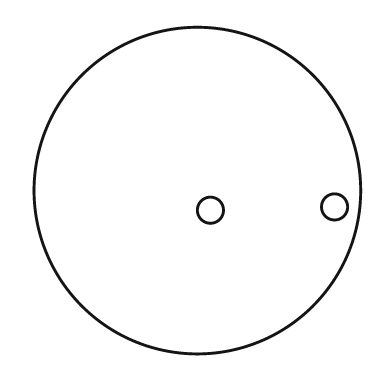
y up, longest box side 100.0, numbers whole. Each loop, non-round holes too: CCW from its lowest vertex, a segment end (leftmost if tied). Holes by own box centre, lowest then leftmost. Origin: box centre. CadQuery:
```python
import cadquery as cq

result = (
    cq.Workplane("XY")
    .moveTo(0.0, 0.0)
    .circle(50.0)
    .moveTo(4.0, -6.0)
    .circle(4.0)
    .moveTo(42.0, -5.0)
    .circle(4.0)
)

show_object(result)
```